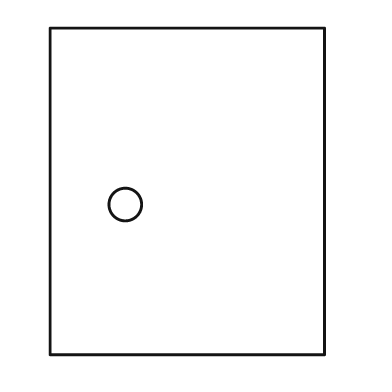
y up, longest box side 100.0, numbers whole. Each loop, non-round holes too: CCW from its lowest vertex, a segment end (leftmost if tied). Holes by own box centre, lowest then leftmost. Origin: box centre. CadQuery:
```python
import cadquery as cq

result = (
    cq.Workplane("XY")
    .moveTo(-42.0, -50.0)
    .lineTo(42.0, -50.0)
    .lineTo(42.0, 50.0)
    .lineTo(-42.0, 50.0)
    .close()
    .moveTo(-19.0, -4.0)
    .circle(5.0)
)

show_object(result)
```